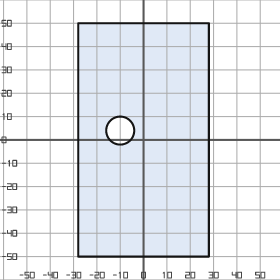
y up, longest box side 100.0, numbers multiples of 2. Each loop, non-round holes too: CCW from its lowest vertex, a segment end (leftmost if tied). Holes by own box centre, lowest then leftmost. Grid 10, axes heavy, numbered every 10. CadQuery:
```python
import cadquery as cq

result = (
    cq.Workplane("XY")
    .moveTo(-28.0, -50.0)
    .lineTo(28.0, -50.0)
    .lineTo(28.0, 50.0)
    .lineTo(-28.0, 50.0)
    .close()
    .moveTo(-10.0, 4.0)
    .circle(6.0)
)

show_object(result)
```